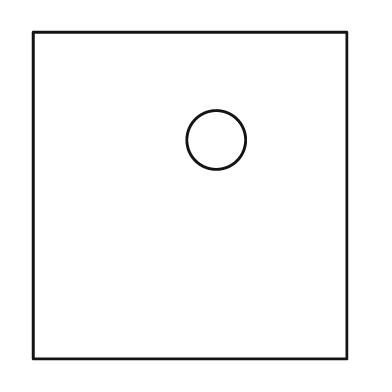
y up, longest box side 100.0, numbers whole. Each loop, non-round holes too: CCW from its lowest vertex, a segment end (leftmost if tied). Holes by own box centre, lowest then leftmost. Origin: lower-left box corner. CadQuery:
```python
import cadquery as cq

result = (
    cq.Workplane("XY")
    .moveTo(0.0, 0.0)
    .lineTo(96.0, 0.0)
    .lineTo(96.0, 100.0)
    .lineTo(0.0, 100.0)
    .close()
    .moveTo(56.0, 67.0)
    .circle(9.0)
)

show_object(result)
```